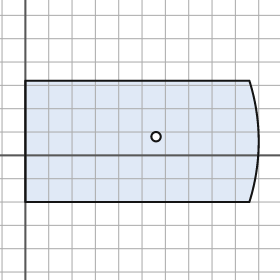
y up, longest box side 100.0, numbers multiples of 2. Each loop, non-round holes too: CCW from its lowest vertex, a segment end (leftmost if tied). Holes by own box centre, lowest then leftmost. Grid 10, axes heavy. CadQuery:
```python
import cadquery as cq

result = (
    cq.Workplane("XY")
    .moveTo(0.0, -20.0)
    .lineTo(96.0, -20.0)
    .threePointArc((100.0, 6.0), (96.0, 32.0))
    .lineTo(0.0, 32.0)
    .close()
    .moveTo(56.0, 8.0)
    .circle(2.0)
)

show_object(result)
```